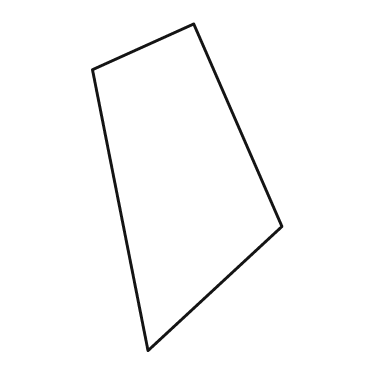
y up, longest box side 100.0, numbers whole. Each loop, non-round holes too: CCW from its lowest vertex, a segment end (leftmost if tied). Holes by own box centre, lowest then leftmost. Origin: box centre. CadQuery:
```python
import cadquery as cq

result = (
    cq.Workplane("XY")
    .moveTo(-12.0, -50.0)
    .lineTo(29.0, -12.0)
    .lineTo(2.0, 50.0)
    .lineTo(-29.0, 36.0)
    .close()
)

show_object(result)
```